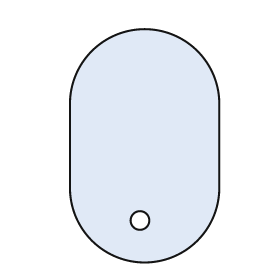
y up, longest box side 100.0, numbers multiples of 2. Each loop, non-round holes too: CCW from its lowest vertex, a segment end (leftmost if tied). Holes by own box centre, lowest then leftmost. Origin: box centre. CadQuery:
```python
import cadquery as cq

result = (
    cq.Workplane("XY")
    .moveTo(-32.0, -18.0)
    .threePointArc((0.0, -50.0), (32.0, -18.0))
    .lineTo(32.0, 18.0)
    .threePointArc((0.0, 50.0), (-32.0, 18.0))
    .close()
    .moveTo(-2.0, -32.0)
    .circle(4.0)
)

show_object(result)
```